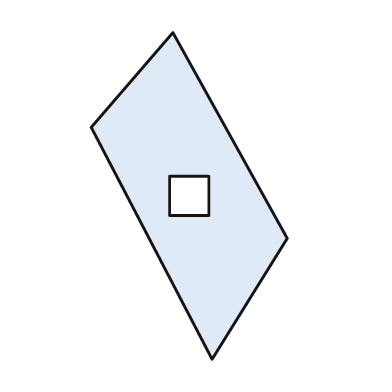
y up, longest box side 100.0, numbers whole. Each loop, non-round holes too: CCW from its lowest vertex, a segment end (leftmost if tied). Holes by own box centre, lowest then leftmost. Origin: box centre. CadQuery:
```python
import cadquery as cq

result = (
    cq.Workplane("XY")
    .moveTo(7.0, -50.0)
    .lineTo(30.0, -13.0)
    .lineTo(-5.0, 50.0)
    .lineTo(-30.0, 21.0)
    .close()
    .moveTo(-6.0, -6.0)
    .lineTo(6.0, -6.0)
    .lineTo(6.0, 6.0)
    .lineTo(-6.0, 6.0)
    .close()
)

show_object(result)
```